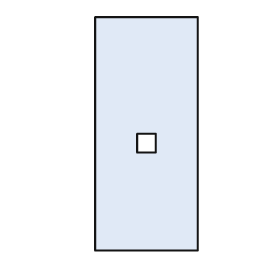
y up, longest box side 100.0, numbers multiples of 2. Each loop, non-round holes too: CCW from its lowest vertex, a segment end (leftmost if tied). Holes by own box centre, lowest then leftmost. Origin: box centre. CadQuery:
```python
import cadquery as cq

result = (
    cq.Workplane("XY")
    .moveTo(-22.0, -50.0)
    .lineTo(22.0, -50.0)
    .lineTo(22.0, 50.0)
    .lineTo(-22.0, 50.0)
    .close()
    .moveTo(-4.0, -8.0)
    .lineTo(4.0, -8.0)
    .lineTo(4.0, 0.0)
    .lineTo(-4.0, 0.0)
    .close()
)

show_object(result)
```